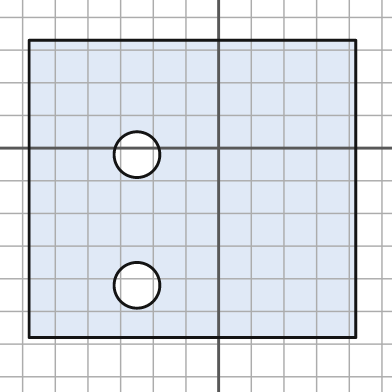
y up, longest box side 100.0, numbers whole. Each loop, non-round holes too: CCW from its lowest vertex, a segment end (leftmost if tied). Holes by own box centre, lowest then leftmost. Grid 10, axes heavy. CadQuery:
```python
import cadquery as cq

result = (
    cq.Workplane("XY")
    .moveTo(-58.0, -58.0)
    .lineTo(42.0, -58.0)
    .lineTo(42.0, 33.0)
    .lineTo(-58.0, 33.0)
    .close()
    .moveTo(-25.0, -42.0)
    .circle(7.0)
    .moveTo(-25.0, -2.0)
    .circle(7.0)
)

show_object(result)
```